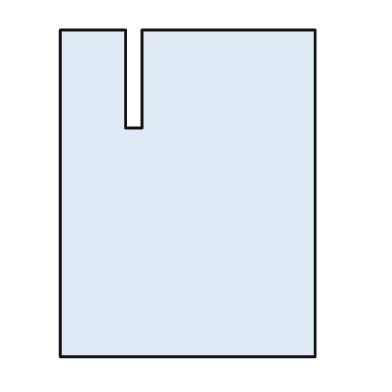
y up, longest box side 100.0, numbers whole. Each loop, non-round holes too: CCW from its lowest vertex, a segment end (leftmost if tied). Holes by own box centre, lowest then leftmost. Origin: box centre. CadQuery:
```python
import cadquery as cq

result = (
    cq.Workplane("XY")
    .moveTo(-39.0, -50.0)
    .lineTo(39.0, -50.0)
    .lineTo(39.0, 50.0)
    .lineTo(-14.0, 50.0)
    .lineTo(-14.0, 20.0)
    .lineTo(-19.0, 20.0)
    .lineTo(-19.0, 50.0)
    .lineTo(-39.0, 50.0)
    .close()
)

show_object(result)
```